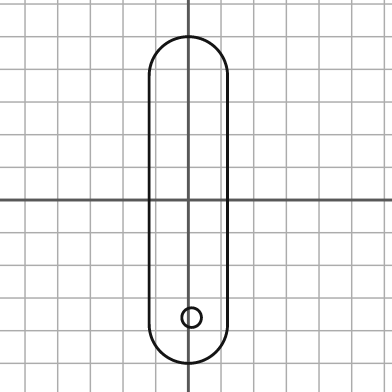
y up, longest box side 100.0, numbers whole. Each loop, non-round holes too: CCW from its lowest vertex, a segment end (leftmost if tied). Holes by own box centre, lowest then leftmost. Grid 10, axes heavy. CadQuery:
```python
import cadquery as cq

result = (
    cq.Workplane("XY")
    .moveTo(-12.0, -38.0)
    .threePointArc((0.0, -50.0), (12.0, -38.0))
    .lineTo(12.0, 38.0)
    .threePointArc((0.0, 50.0), (-12.0, 38.0))
    .close()
    .moveTo(1.0, -36.0)
    .circle(3.0)
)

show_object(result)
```